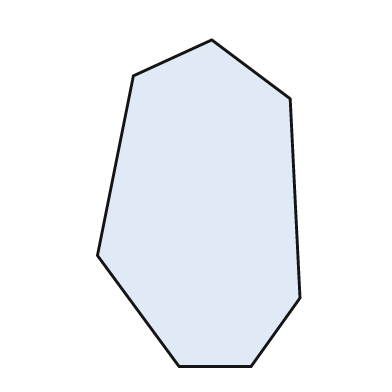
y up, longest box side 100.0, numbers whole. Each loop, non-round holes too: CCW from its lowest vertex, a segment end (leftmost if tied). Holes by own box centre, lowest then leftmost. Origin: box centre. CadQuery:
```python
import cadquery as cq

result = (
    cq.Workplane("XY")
    .moveTo(-6.0, -50.0)
    .lineTo(16.0, -50.0)
    .lineTo(31.0, -29.0)
    .lineTo(28.0, 32.0)
    .lineTo(4.0, 50.0)
    .lineTo(-20.0, 39.0)
    .lineTo(-31.0, -16.0)
    .close()
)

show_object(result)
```